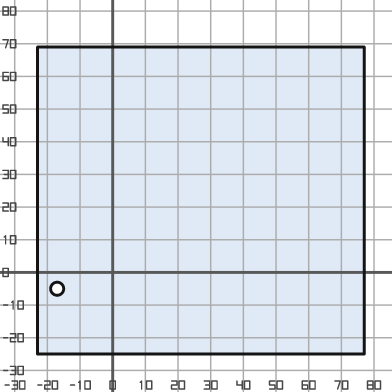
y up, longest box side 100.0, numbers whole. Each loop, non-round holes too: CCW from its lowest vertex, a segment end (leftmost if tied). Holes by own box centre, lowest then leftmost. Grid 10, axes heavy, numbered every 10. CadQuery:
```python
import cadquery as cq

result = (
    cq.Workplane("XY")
    .moveTo(-23.0, -25.0)
    .lineTo(77.0, -25.0)
    .lineTo(77.0, 69.0)
    .lineTo(-23.0, 69.0)
    .close()
    .moveTo(-17.0, -5.0)
    .circle(2.0)
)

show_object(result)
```